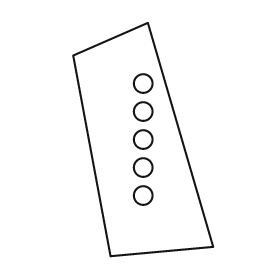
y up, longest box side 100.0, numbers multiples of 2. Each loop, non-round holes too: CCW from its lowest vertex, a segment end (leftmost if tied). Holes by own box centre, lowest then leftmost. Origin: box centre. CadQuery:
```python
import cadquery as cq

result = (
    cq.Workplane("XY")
    .moveTo(-14.0, -50.0)
    .lineTo(30.0, -46.0)
    .lineTo(2.0, 50.0)
    .lineTo(-30.0, 36.0)
    .close()
    .moveTo(0.0, -24.0)
    .circle(4.0)
    .moveTo(0.0, -12.0)
    .circle(4.0)
    .moveTo(0.0, 0.0)
    .circle(4.0)
    .moveTo(0.0, 12.0)
    .circle(4.0)
    .moveTo(0.0, 24.0)
    .circle(4.0)
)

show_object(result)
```